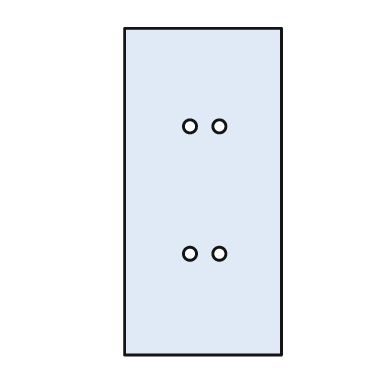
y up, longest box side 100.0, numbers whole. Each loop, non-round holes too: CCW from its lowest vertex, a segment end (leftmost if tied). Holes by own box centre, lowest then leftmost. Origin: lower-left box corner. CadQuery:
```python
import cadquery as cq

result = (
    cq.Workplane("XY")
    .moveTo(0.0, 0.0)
    .lineTo(48.0, 0.0)
    .lineTo(48.0, 100.0)
    .lineTo(0.0, 100.0)
    .close()
    .moveTo(20.0, 31.0)
    .circle(2.0)
    .moveTo(29.0, 31.0)
    .circle(2.0)
    .moveTo(20.0, 70.0)
    .circle(2.0)
    .moveTo(29.0, 70.0)
    .circle(2.0)
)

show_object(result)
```